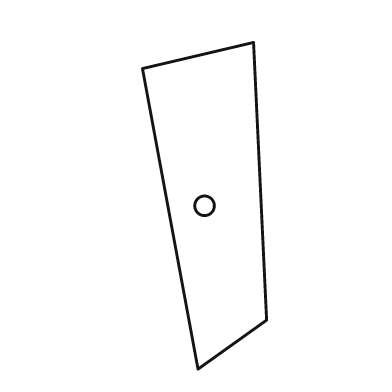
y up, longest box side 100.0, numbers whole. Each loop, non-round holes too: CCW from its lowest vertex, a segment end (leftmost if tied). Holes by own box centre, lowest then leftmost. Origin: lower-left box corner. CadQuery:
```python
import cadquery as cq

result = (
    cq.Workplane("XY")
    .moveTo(17.0, 0.0)
    .lineTo(38.0, 15.0)
    .lineTo(34.0, 100.0)
    .lineTo(0.0, 92.0)
    .close()
    .moveTo(19.0, 50.0)
    .circle(3.0)
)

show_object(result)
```